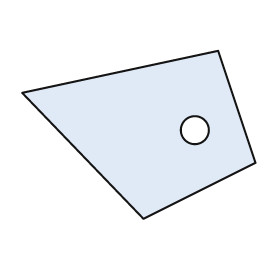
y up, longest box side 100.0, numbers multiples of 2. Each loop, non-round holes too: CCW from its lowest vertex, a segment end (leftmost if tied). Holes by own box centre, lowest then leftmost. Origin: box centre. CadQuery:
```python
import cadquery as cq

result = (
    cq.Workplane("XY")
    .moveTo(2.0, -36.0)
    .lineTo(50.0, -12.0)
    .lineTo(34.0, 36.0)
    .lineTo(-50.0, 18.0)
    .close()
    .moveTo(24.0, 2.0)
    .circle(6.0)
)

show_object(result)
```